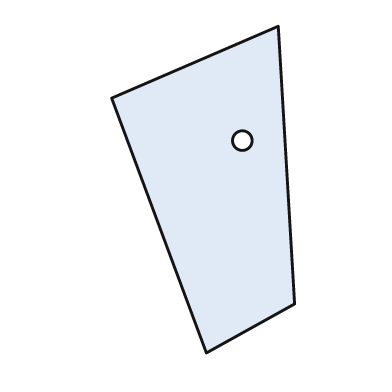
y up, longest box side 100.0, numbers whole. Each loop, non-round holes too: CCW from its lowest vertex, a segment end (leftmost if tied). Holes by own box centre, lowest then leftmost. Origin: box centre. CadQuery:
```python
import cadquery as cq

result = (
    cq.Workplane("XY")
    .moveTo(1.0, -50.0)
    .lineTo(28.0, -35.0)
    .lineTo(23.0, 50.0)
    .lineTo(-28.0, 28.0)
    .close()
    .moveTo(12.0, 15.0)
    .circle(3.0)
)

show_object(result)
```